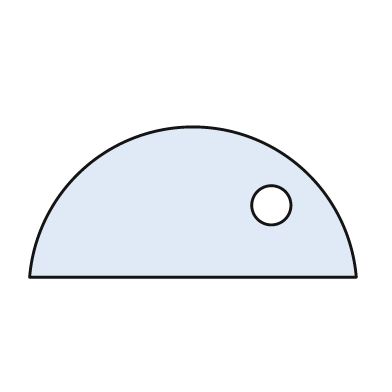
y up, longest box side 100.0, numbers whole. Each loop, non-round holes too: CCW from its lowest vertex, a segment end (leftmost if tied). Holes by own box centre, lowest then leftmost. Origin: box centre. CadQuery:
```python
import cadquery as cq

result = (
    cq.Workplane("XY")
    .moveTo(-50.0, -23.0)
    .lineTo(50.0, -23.0)
    .threePointArc((0.0, 23.0), (-50.0, -23.0))
    .close()
    .moveTo(24.0, -1.0)
    .circle(6.0)
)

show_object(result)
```